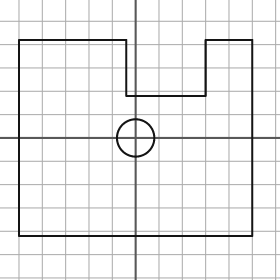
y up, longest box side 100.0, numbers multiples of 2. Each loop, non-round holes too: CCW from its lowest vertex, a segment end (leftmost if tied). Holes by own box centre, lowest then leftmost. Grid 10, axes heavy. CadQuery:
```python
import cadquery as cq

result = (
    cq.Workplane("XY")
    .moveTo(-50.0, -42.0)
    .lineTo(50.0, -42.0)
    .lineTo(50.0, 42.0)
    .lineTo(30.0, 42.0)
    .lineTo(30.0, 18.0)
    .lineTo(-4.0, 18.0)
    .lineTo(-4.0, 42.0)
    .lineTo(-50.0, 42.0)
    .close()
    .moveTo(0.0, 0.0)
    .circle(8.0)
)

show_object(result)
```